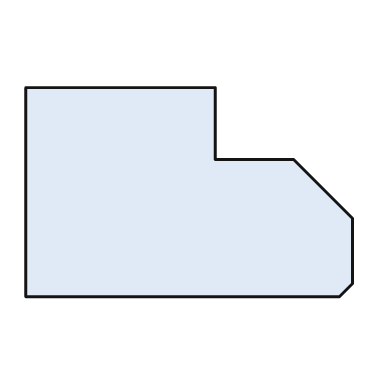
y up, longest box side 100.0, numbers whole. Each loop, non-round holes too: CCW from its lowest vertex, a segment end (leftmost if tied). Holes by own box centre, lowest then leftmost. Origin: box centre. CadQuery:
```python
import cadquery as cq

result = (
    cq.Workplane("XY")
    .moveTo(-50.0, -32.0)
    .lineTo(46.0, -32.0)
    .lineTo(50.0, -28.0)
    .lineTo(50.0, -8.0)
    .lineTo(32.0, 10.0)
    .lineTo(8.0, 10.0)
    .lineTo(8.0, 32.0)
    .lineTo(-50.0, 32.0)
    .close()
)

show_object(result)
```